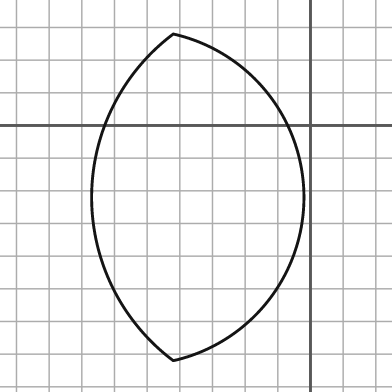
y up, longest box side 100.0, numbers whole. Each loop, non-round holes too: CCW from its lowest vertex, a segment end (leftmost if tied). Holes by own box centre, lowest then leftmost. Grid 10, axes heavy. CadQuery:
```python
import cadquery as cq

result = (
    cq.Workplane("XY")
    .moveTo(-42.0, -72.0)
    .threePointArc((-2.0, -22.0), (-42.0, 28.0))
    .threePointArc((-67.0, -22.0), (-42.0, -72.0))
    .close()
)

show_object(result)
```